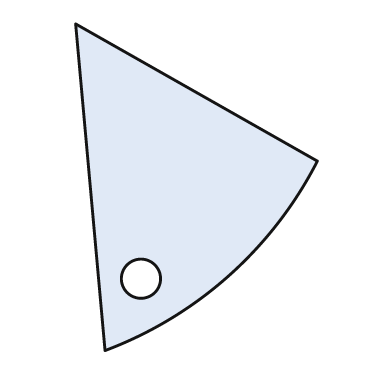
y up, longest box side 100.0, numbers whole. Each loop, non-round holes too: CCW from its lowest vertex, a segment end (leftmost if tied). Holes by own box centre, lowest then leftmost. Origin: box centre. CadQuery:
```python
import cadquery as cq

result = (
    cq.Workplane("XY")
    .moveTo(-28.0, -50.0)
    .threePointArc((10.0, -27.0), (37.0, 8.0))
    .lineTo(-37.0, 50.0)
    .close()
    .moveTo(-17.0, -28.0)
    .circle(6.0)
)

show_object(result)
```